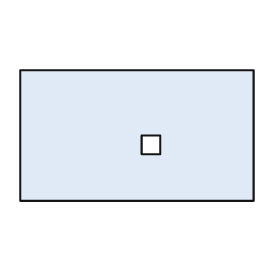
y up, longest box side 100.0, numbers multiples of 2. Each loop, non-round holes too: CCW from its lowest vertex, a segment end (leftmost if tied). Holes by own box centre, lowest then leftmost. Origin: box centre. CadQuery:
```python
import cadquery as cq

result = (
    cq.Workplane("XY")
    .moveTo(-50.0, -28.0)
    .lineTo(50.0, -28.0)
    .lineTo(50.0, 28.0)
    .lineTo(-50.0, 28.0)
    .close()
    .moveTo(2.0, -8.0)
    .lineTo(10.0, -8.0)
    .lineTo(10.0, 0.0)
    .lineTo(2.0, 0.0)
    .close()
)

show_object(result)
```